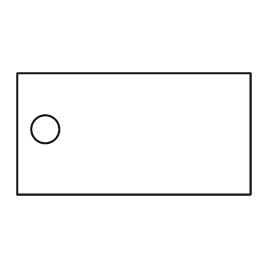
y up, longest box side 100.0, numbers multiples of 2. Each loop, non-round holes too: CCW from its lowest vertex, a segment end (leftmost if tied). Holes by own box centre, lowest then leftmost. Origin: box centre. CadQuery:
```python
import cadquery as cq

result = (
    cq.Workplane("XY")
    .moveTo(-50.0, -26.0)
    .lineTo(50.0, -26.0)
    .lineTo(50.0, 26.0)
    .lineTo(-50.0, 26.0)
    .close()
    .moveTo(-38.0, 2.0)
    .circle(6.0)
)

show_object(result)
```